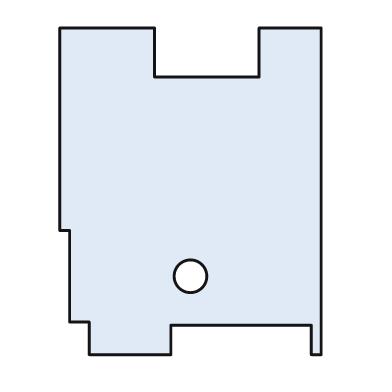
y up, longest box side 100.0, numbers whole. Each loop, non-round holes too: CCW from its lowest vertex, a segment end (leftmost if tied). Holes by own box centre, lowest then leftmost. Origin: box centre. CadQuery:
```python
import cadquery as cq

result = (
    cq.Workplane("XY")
    .moveTo(-31.0, -50.0)
    .lineTo(-6.0, -50.0)
    .lineTo(-6.0, -41.0)
    .lineTo(37.0, -41.0)
    .lineTo(37.0, -50.0)
    .lineTo(40.0, -50.0)
    .lineTo(40.0, 50.0)
    .lineTo(21.0, 50.0)
    .lineTo(21.0, 35.0)
    .lineTo(-11.0, 35.0)
    .lineTo(-11.0, 50.0)
    .lineTo(-40.0, 50.0)
    .lineTo(-40.0, -12.0)
    .lineTo(-37.0, -12.0)
    .lineTo(-37.0, -40.0)
    .lineTo(-31.0, -40.0)
    .close()
    .moveTo(0.0, -26.0)
    .circle(5.0)
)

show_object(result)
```